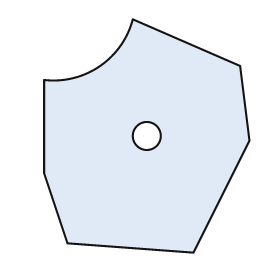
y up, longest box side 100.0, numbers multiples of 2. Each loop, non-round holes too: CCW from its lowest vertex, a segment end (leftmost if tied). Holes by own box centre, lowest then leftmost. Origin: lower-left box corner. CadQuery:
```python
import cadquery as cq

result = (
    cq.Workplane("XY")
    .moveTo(64.0, 0.0)
    .lineTo(88.0, 48.0)
    .lineTo(84.0, 80.0)
    .lineTo(38.0, 100.0)
    .threePointArc((24.0, 80.0), (0.0, 74.0))
    .lineTo(0.0, 34.0)
    .lineTo(10.0, 4.0)
    .close()
    .moveTo(44.0, 50.0)
    .circle(6.0)
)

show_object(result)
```